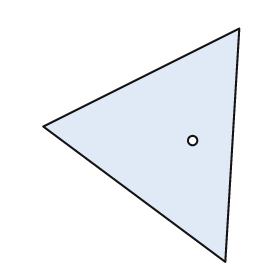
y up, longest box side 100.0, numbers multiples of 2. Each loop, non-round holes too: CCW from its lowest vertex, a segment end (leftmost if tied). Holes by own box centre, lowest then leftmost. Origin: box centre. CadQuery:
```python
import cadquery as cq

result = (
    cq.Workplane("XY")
    .moveTo(36.0, -50.0)
    .lineTo(42.0, 50.0)
    .lineTo(-42.0, 8.0)
    .close()
    .moveTo(22.0, 2.0)
    .circle(2.0)
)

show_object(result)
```